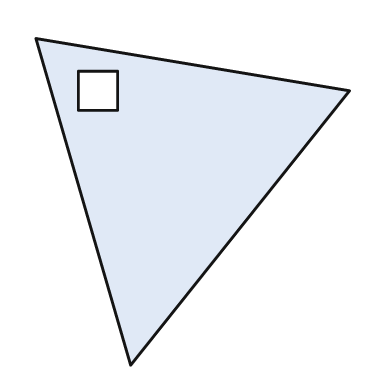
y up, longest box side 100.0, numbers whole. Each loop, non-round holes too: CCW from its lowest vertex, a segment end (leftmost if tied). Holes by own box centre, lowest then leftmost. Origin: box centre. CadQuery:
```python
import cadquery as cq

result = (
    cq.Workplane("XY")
    .moveTo(-19.0, -50.0)
    .lineTo(48.0, 34.0)
    .lineTo(-48.0, 50.0)
    .close()
    .moveTo(-35.0, 28.0)
    .lineTo(-23.0, 28.0)
    .lineTo(-23.0, 40.0)
    .lineTo(-35.0, 40.0)
    .close()
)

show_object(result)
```